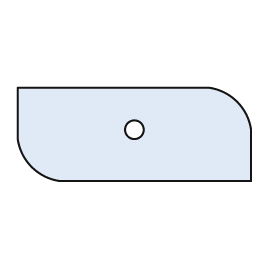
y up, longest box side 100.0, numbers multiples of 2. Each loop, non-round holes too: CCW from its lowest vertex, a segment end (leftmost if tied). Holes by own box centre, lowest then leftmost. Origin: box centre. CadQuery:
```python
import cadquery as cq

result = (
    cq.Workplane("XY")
    .moveTo(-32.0, -20.0)
    .lineTo(50.0, -20.0)
    .lineTo(50.0, 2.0)
    .threePointArc((44.0, 14.0), (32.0, 20.0))
    .lineTo(-50.0, 20.0)
    .lineTo(-50.0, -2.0)
    .threePointArc((-44.0, -14.0), (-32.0, -20.0))
    .close()
    .moveTo(0.0, 2.0)
    .circle(4.0)
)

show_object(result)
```